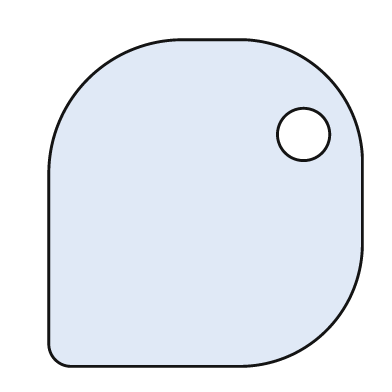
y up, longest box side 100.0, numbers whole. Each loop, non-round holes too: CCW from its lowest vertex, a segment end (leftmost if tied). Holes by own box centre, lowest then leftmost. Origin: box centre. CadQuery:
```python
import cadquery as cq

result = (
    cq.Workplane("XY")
    .moveTo(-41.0, -50.0)
    .lineTo(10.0, -50.0)
    .threePointArc((37.0, -39.0), (48.0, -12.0))
    .lineTo(48.0, 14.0)
    .threePointArc((37.0, 39.0), (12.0, 50.0))
    .lineTo(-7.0, 50.0)
    .threePointArc((-36.0, 38.0), (-48.0, 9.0))
    .lineTo(-48.0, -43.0)
    .threePointArc((-46.0, -48.0), (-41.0, -50.0))
    .close()
    .moveTo(30.0, 21.0)
    .circle(8.0)
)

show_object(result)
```